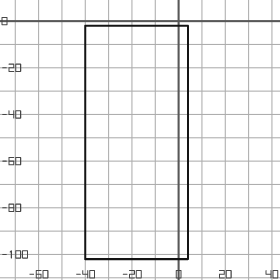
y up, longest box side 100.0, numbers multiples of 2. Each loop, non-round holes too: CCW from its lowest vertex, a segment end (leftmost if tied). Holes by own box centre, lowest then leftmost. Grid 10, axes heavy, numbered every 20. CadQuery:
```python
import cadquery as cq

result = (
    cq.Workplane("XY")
    .moveTo(-40.0, -102.0)
    .lineTo(4.0, -102.0)
    .lineTo(4.0, -2.0)
    .lineTo(-40.0, -2.0)
    .close()
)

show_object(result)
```